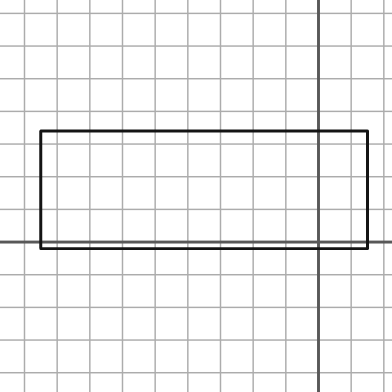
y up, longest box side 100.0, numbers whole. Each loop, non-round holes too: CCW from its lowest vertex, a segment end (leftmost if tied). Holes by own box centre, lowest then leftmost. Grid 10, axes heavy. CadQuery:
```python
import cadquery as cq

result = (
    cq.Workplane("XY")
    .moveTo(-85.0, -2.0)
    .lineTo(15.0, -2.0)
    .lineTo(15.0, 34.0)
    .lineTo(-85.0, 34.0)
    .close()
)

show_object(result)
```